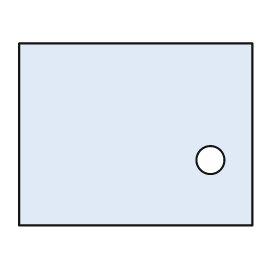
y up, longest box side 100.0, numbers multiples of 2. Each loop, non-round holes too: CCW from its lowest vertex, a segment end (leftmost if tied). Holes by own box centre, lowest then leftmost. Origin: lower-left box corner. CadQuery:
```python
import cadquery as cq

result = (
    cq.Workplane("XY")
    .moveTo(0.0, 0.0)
    .lineTo(100.0, 0.0)
    .lineTo(100.0, 78.0)
    .lineTo(0.0, 78.0)
    .close()
    .moveTo(82.0, 28.0)
    .circle(6.0)
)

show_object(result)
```